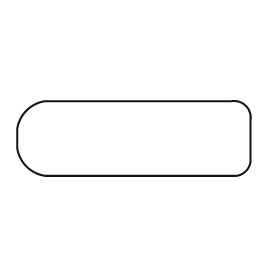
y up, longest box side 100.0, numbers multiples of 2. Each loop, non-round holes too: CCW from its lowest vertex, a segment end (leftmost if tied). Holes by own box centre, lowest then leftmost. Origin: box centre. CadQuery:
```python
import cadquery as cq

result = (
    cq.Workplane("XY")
    .moveTo(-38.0, -16.0)
    .lineTo(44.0, -16.0)
    .threePointArc((48.0, -14.0), (50.0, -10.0))
    .lineTo(50.0, 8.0)
    .threePointArc((48.0, 14.0), (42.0, 16.0))
    .lineTo(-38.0, 16.0)
    .threePointArc((-46.0, 12.0), (-50.0, 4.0))
    .lineTo(-50.0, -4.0)
    .threePointArc((-46.0, -12.0), (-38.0, -16.0))
    .close()
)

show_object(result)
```